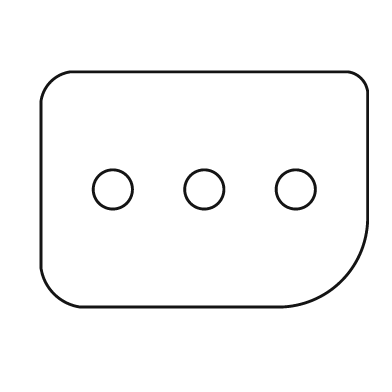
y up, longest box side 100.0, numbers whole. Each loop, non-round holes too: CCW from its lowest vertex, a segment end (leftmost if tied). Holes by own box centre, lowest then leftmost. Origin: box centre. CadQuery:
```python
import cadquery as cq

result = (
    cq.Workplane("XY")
    .moveTo(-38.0, -36.0)
    .lineTo(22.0, -36.0)
    .threePointArc((42.0, -28.0), (50.0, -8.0))
    .lineTo(50.0, 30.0)
    .threePointArc((48.0, 34.0), (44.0, 36.0))
    .lineTo(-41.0, 36.0)
    .threePointArc((-47.0, 33.0), (-50.0, 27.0))
    .lineTo(-50.0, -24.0)
    .threePointArc((-46.0, -32.0), (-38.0, -36.0))
    .close()
    .moveTo(-28.0, 0.0)
    .circle(6.0)
    .moveTo(0.0, 0.0)
    .circle(6.0)
    .moveTo(28.0, 0.0)
    .circle(6.0)
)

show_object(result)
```